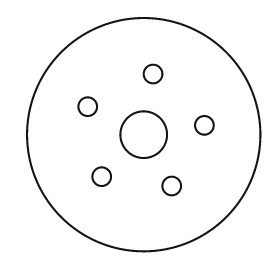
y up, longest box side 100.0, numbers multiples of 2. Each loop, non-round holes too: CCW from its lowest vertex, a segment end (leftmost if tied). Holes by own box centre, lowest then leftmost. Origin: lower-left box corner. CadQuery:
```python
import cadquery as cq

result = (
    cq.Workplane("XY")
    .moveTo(50.0, 50.0)
    .circle(50.0)
    .moveTo(62.0, 28.0)
    .circle(4.0)
    .moveTo(32.0, 32.0)
    .circle(4.0)
    .moveTo(50.0, 50.0)
    .circle(10.0)
    .moveTo(76.0, 54.0)
    .circle(4.0)
    .moveTo(26.0, 62.0)
    .circle(4.0)
    .moveTo(54.0, 76.0)
    .circle(4.0)
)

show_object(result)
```